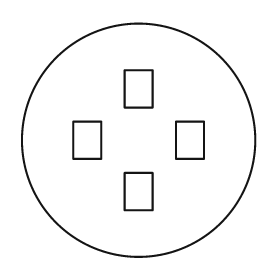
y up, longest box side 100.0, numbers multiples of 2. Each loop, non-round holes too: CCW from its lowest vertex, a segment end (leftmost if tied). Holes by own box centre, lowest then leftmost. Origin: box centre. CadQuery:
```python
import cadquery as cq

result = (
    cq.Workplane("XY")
    .moveTo(0.0, 0.0)
    .circle(50.0)
    .moveTo(-6.0, -30.0)
    .lineTo(6.0, -30.0)
    .lineTo(6.0, -14.0)
    .lineTo(-6.0, -14.0)
    .close()
    .moveTo(-28.0, -8.0)
    .lineTo(-16.0, -8.0)
    .lineTo(-16.0, 8.0)
    .lineTo(-28.0, 8.0)
    .close()
    .moveTo(16.0, -8.0)
    .lineTo(28.0, -8.0)
    .lineTo(28.0, 8.0)
    .lineTo(16.0, 8.0)
    .close()
    .moveTo(-6.0, 14.0)
    .lineTo(6.0, 14.0)
    .lineTo(6.0, 30.0)
    .lineTo(-6.0, 30.0)
    .close()
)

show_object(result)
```